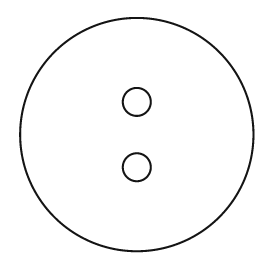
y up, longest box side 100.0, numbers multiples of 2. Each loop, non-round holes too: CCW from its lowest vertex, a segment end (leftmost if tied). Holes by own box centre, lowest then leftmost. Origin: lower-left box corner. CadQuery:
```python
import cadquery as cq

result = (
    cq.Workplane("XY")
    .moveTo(50.0, 50.0)
    .circle(50.0)
    .moveTo(50.0, 36.0)
    .circle(6.0)
    .moveTo(50.0, 64.0)
    .circle(6.0)
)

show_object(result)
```